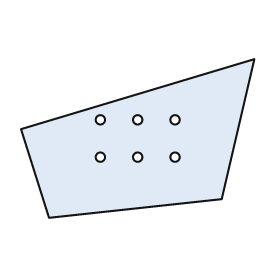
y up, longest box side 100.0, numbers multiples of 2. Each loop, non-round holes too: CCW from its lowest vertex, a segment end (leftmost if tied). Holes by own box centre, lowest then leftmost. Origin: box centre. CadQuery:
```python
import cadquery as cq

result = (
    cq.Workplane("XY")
    .moveTo(-38.0, -34.0)
    .lineTo(36.0, -26.0)
    .lineTo(50.0, 34.0)
    .lineTo(-50.0, 4.0)
    .close()
    .moveTo(-16.0, -8.0)
    .circle(2.0)
    .moveTo(0.0, -8.0)
    .circle(2.0)
    .moveTo(16.0, -8.0)
    .circle(2.0)
    .moveTo(-16.0, 8.0)
    .circle(2.0)
    .moveTo(0.0, 8.0)
    .circle(2.0)
    .moveTo(16.0, 8.0)
    .circle(2.0)
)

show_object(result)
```